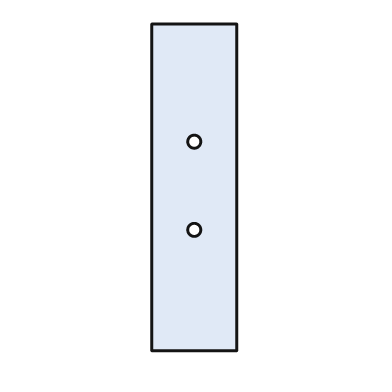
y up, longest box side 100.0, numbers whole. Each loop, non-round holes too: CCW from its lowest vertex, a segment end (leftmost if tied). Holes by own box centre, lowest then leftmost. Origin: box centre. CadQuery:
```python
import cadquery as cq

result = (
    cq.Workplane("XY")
    .moveTo(-13.0, -50.0)
    .lineTo(13.0, -50.0)
    .lineTo(13.0, 50.0)
    .lineTo(-13.0, 50.0)
    .close()
    .moveTo(0.0, -13.0)
    .circle(2.0)
    .moveTo(0.0, 14.0)
    .circle(2.0)
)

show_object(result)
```